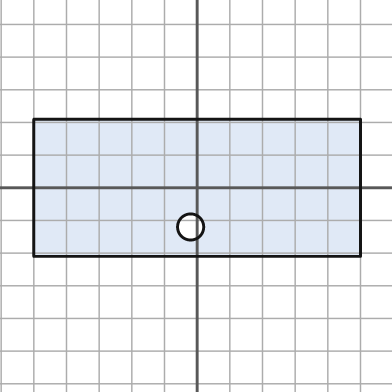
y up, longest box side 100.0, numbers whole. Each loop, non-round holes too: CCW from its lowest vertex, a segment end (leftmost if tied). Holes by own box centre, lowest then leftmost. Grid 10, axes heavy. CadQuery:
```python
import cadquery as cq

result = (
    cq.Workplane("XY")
    .moveTo(-50.0, -21.0)
    .lineTo(50.0, -21.0)
    .lineTo(50.0, 21.0)
    .lineTo(-50.0, 21.0)
    .close()
    .moveTo(-2.0, -12.0)
    .circle(4.0)
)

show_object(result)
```